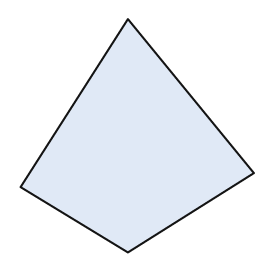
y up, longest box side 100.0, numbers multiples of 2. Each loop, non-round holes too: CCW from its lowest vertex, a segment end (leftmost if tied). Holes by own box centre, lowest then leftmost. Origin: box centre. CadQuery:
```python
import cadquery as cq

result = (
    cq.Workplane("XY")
    .moveTo(-4.0, -50.0)
    .lineTo(50.0, -16.0)
    .lineTo(-4.0, 50.0)
    .lineTo(-50.0, -22.0)
    .close()
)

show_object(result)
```